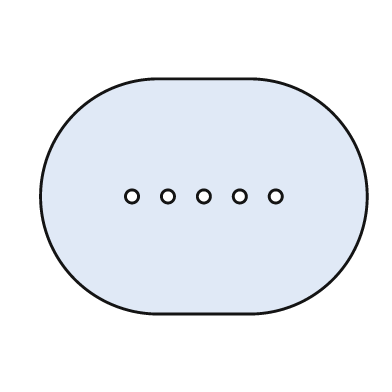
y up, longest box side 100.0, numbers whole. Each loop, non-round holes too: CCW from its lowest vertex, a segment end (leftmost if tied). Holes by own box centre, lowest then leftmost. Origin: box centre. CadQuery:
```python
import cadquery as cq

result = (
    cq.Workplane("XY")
    .moveTo(-14.0, -36.0)
    .lineTo(14.0, -36.0)
    .threePointArc((50.0, 0.0), (14.0, 36.0))
    .lineTo(-14.0, 36.0)
    .threePointArc((-50.0, 0.0), (-14.0, -36.0))
    .close()
    .moveTo(-22.0, 0.0)
    .circle(2.0)
    .moveTo(-11.0, 0.0)
    .circle(2.0)
    .moveTo(0.0, 0.0)
    .circle(2.0)
    .moveTo(11.0, 0.0)
    .circle(2.0)
    .moveTo(22.0, 0.0)
    .circle(2.0)
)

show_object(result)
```